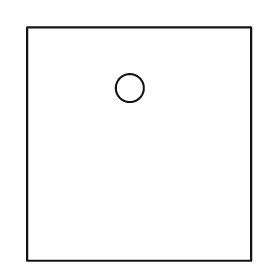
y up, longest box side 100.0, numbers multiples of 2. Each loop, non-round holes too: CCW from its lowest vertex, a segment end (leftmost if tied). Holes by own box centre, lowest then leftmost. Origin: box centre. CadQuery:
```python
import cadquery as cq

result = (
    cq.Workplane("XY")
    .moveTo(-48.0, -50.0)
    .lineTo(48.0, -50.0)
    .lineTo(48.0, 50.0)
    .lineTo(-48.0, 50.0)
    .close()
    .moveTo(-4.0, 24.0)
    .circle(6.0)
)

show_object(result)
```